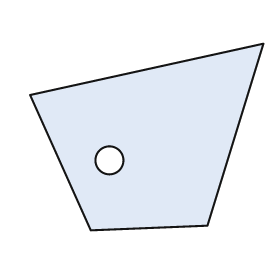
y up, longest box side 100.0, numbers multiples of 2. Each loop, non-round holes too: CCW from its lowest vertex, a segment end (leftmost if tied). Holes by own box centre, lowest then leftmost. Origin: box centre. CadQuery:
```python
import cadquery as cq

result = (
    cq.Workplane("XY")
    .moveTo(-24.0, -40.0)
    .lineTo(26.0, -38.0)
    .lineTo(50.0, 40.0)
    .lineTo(-50.0, 18.0)
    .close()
    .moveTo(-16.0, -10.0)
    .circle(6.0)
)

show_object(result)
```